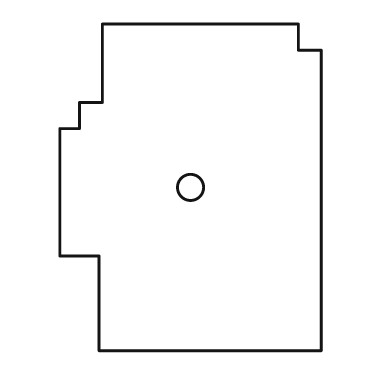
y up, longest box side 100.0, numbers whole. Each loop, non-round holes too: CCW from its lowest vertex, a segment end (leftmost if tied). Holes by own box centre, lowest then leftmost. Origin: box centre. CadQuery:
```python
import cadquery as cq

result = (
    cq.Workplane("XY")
    .moveTo(-28.0, -50.0)
    .lineTo(40.0, -50.0)
    .lineTo(40.0, 42.0)
    .lineTo(33.0, 42.0)
    .lineTo(33.0, 50.0)
    .lineTo(-27.0, 50.0)
    .lineTo(-27.0, 26.0)
    .lineTo(-34.0, 26.0)
    .lineTo(-34.0, 18.0)
    .lineTo(-40.0, 18.0)
    .lineTo(-40.0, -21.0)
    .lineTo(-28.0, -21.0)
    .close()
    .moveTo(0.0, 0.0)
    .circle(4.0)
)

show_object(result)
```